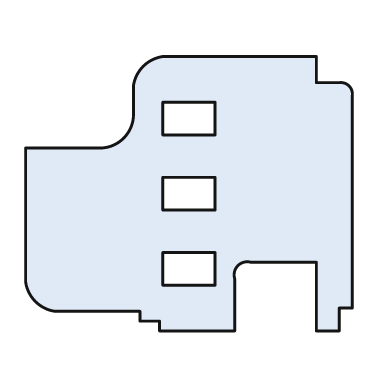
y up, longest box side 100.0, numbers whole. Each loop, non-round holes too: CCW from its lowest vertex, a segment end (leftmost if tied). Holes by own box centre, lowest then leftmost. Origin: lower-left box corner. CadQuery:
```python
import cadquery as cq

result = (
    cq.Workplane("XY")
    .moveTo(41.0, 0.0)
    .lineTo(64.0, 0.0)
    .lineTo(64.0, 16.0)
    .threePointArc((65.0, 20.0), (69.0, 21.0))
    .lineTo(89.0, 21.0)
    .lineTo(89.0, 0.0)
    .lineTo(96.0, 0.0)
    .lineTo(96.0, 7.0)
    .lineTo(100.0, 7.0)
    .lineTo(100.0, 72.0)
    .threePointArc((99.0, 75.0), (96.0, 76.0))
    .lineTo(89.0, 76.0)
    .lineTo(89.0, 84.0)
    .lineTo(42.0, 84.0)
    .threePointArc((36.0, 81.0), (33.0, 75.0))
    .lineTo(33.0, 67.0)
    .threePointArc((30.0, 59.0), (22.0, 56.0))
    .lineTo(0.0, 56.0)
    .lineTo(0.0, 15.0)
    .threePointArc((3.0, 9.0), (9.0, 6.0))
    .lineTo(35.0, 6.0)
    .lineTo(35.0, 3.0)
    .lineTo(41.0, 3.0)
    .close()
    .moveTo(42.0, 14.0)
    .lineTo(58.0, 14.0)
    .lineTo(58.0, 24.0)
    .lineTo(42.0, 24.0)
    .close()
    .moveTo(42.0, 37.0)
    .lineTo(58.0, 37.0)
    .lineTo(58.0, 47.0)
    .lineTo(42.0, 47.0)
    .close()
    .moveTo(42.0, 60.0)
    .lineTo(58.0, 60.0)
    .lineTo(58.0, 70.0)
    .lineTo(42.0, 70.0)
    .close()
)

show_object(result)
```